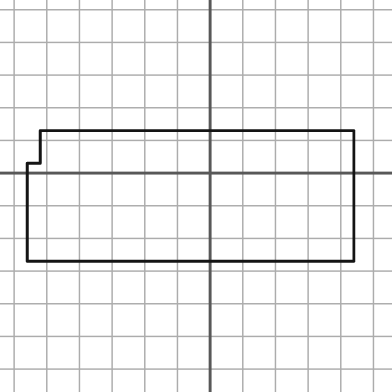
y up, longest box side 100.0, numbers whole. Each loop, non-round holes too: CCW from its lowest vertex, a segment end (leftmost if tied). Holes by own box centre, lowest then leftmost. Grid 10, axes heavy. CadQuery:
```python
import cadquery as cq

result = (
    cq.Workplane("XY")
    .moveTo(-56.0, -27.0)
    .lineTo(44.0, -27.0)
    .lineTo(44.0, 13.0)
    .lineTo(-52.0, 13.0)
    .lineTo(-52.0, 3.0)
    .lineTo(-56.0, 3.0)
    .close()
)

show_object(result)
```